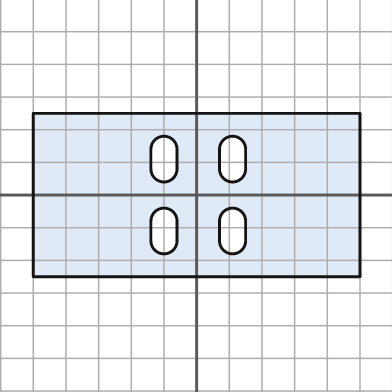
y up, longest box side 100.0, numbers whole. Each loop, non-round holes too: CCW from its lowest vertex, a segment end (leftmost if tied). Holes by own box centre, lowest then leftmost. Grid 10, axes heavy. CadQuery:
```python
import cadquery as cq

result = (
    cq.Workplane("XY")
    .moveTo(-50.0, -25.0)
    .lineTo(50.0, -25.0)
    .lineTo(50.0, 25.0)
    .lineTo(-50.0, 25.0)
    .close()
    .moveTo(-14.0, -14.0)
    .threePointArc((-10.0, -18.0), (-6.0, -14.0))
    .lineTo(-6.0, -8.0)
    .threePointArc((-10.0, -4.0), (-14.0, -8.0))
    .close()
    .moveTo(7.0, -14.0)
    .threePointArc((11.0, -18.0), (15.0, -14.0))
    .lineTo(15.0, -8.0)
    .threePointArc((11.0, -4.0), (7.0, -8.0))
    .close()
    .moveTo(-14.0, 8.0)
    .threePointArc((-10.0, 4.0), (-6.0, 8.0))
    .lineTo(-6.0, 14.0)
    .threePointArc((-10.0, 18.0), (-14.0, 14.0))
    .close()
    .moveTo(7.0, 8.0)
    .threePointArc((11.0, 4.0), (15.0, 8.0))
    .lineTo(15.0, 14.0)
    .threePointArc((11.0, 18.0), (7.0, 14.0))
    .close()
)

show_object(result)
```